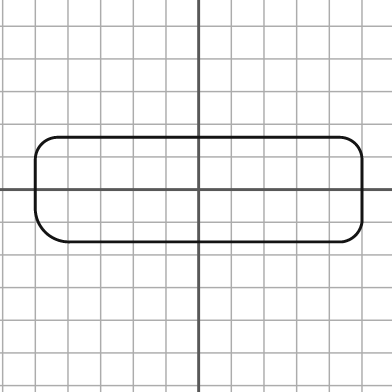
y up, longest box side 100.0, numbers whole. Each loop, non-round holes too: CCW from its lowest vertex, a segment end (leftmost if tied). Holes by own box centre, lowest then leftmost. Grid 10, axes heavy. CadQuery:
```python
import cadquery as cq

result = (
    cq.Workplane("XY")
    .moveTo(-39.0, -16.0)
    .lineTo(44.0, -16.0)
    .threePointArc((48.0, -14.0), (50.0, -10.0))
    .lineTo(50.0, 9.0)
    .threePointArc((48.0, 14.0), (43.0, 16.0))
    .lineTo(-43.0, 16.0)
    .threePointArc((-48.0, 14.0), (-50.0, 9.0))
    .lineTo(-50.0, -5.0)
    .threePointArc((-47.0, -13.0), (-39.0, -16.0))
    .close()
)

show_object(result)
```